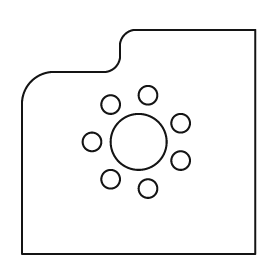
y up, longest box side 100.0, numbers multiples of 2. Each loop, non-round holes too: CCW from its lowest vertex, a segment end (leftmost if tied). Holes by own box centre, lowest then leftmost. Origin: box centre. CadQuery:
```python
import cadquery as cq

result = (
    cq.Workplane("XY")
    .moveTo(-50.0, -48.0)
    .lineTo(50.0, -48.0)
    .lineTo(50.0, 48.0)
    .lineTo(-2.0, 48.0)
    .threePointArc((-6.0, 46.0), (-8.0, 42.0))
    .lineTo(-8.0, 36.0)
    .threePointArc((-10.0, 32.0), (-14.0, 30.0))
    .lineTo(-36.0, 30.0)
    .threePointArc((-46.0, 26.0), (-50.0, 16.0))
    .close()
    .moveTo(4.0, -20.0)
    .circle(4.0)
    .moveTo(-12.0, -16.0)
    .circle(4.0)
    .moveTo(18.0, -8.0)
    .circle(4.0)
    .moveTo(-20.0, 0.0)
    .circle(4.0)
    .moveTo(0.0, 0.0)
    .circle(12.0)
    .moveTo(18.0, 8.0)
    .circle(4.0)
    .moveTo(-12.0, 16.0)
    .circle(4.0)
    .moveTo(4.0, 20.0)
    .circle(4.0)
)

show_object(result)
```